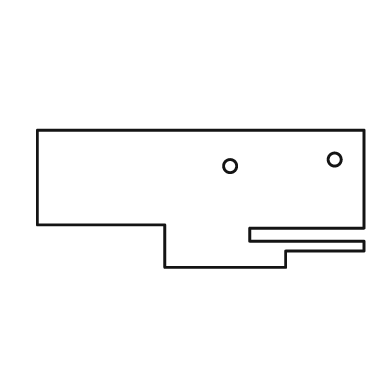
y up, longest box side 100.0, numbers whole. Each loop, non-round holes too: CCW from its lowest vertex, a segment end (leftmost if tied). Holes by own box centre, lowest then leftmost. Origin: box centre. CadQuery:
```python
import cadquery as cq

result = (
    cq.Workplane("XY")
    .moveTo(-11.0, -21.0)
    .lineTo(26.0, -21.0)
    .lineTo(26.0, -16.0)
    .lineTo(50.0, -16.0)
    .lineTo(50.0, -13.0)
    .lineTo(15.0, -13.0)
    .lineTo(15.0, -9.0)
    .lineTo(50.0, -9.0)
    .lineTo(50.0, 21.0)
    .lineTo(-50.0, 21.0)
    .lineTo(-50.0, -8.0)
    .lineTo(-11.0, -8.0)
    .close()
    .moveTo(9.0, 10.0)
    .circle(2.0)
    .moveTo(41.0, 12.0)
    .circle(2.0)
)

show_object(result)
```